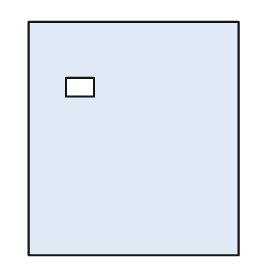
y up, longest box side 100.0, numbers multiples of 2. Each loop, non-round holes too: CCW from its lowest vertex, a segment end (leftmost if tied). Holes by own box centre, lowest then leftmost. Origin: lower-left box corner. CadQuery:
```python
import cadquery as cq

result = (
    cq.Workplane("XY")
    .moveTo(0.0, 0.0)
    .lineTo(90.0, 0.0)
    .lineTo(90.0, 100.0)
    .lineTo(0.0, 100.0)
    .close()
    .moveTo(16.0, 68.0)
    .lineTo(28.0, 68.0)
    .lineTo(28.0, 76.0)
    .lineTo(16.0, 76.0)
    .close()
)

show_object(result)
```